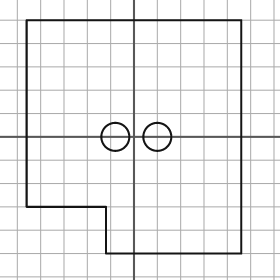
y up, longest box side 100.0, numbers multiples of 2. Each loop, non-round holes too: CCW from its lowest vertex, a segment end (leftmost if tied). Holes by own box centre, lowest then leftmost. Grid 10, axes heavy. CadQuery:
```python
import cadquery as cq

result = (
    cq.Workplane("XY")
    .moveTo(-12.0, -50.0)
    .lineTo(46.0, -50.0)
    .lineTo(46.0, 50.0)
    .lineTo(-46.0, 50.0)
    .lineTo(-46.0, -30.0)
    .lineTo(-12.0, -30.0)
    .close()
    .moveTo(-8.0, 0.0)
    .circle(6.0)
    .moveTo(10.0, 0.0)
    .circle(6.0)
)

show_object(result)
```